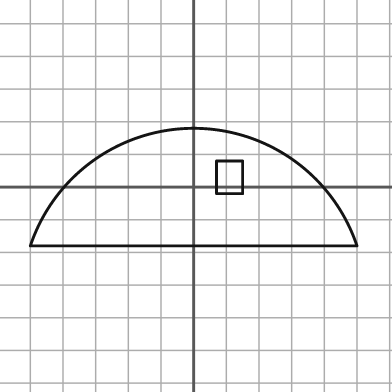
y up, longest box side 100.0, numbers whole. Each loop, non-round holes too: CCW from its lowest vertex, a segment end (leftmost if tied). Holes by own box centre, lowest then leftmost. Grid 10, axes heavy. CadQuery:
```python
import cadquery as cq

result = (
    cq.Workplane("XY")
    .moveTo(-50.0, -18.0)
    .lineTo(50.0, -18.0)
    .threePointArc((0.0, 18.0), (-50.0, -18.0))
    .close()
    .moveTo(7.0, -2.0)
    .lineTo(15.0, -2.0)
    .lineTo(15.0, 8.0)
    .lineTo(7.0, 8.0)
    .close()
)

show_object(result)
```